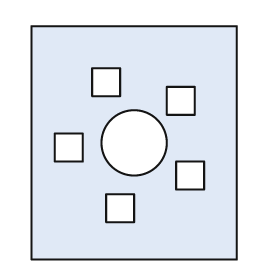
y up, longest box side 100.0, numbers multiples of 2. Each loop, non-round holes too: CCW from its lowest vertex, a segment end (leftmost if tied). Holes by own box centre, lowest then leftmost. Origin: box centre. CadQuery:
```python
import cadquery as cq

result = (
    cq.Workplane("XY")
    .moveTo(-44.0, -50.0)
    .lineTo(44.0, -50.0)
    .lineTo(44.0, 50.0)
    .lineTo(-44.0, 50.0)
    .close()
    .moveTo(-12.0, -34.0)
    .lineTo(0.0, -34.0)
    .lineTo(0.0, -22.0)
    .lineTo(-12.0, -22.0)
    .close()
    .moveTo(18.0, -20.0)
    .lineTo(30.0, -20.0)
    .lineTo(30.0, -8.0)
    .lineTo(18.0, -8.0)
    .close()
    .moveTo(-34.0, -8.0)
    .lineTo(-22.0, -8.0)
    .lineTo(-22.0, 4.0)
    .lineTo(-34.0, 4.0)
    .close()
    .moveTo(0.0, 0.0)
    .circle(14.0)
    .moveTo(14.0, 12.0)
    .lineTo(26.0, 12.0)
    .lineTo(26.0, 24.0)
    .lineTo(14.0, 24.0)
    .close()
    .moveTo(-18.0, 20.0)
    .lineTo(-6.0, 20.0)
    .lineTo(-6.0, 32.0)
    .lineTo(-18.0, 32.0)
    .close()
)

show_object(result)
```